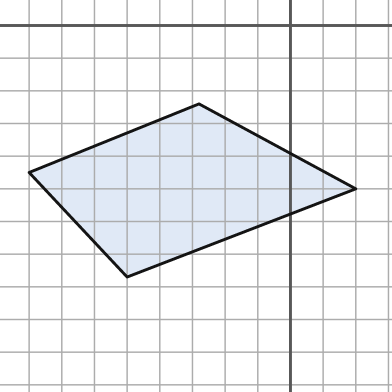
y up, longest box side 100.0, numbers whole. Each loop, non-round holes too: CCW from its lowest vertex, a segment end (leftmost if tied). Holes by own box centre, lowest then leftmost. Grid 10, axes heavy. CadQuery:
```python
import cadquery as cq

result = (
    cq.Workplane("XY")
    .moveTo(-50.0, -77.0)
    .lineTo(20.0, -50.0)
    .lineTo(-28.0, -24.0)
    .lineTo(-80.0, -45.0)
    .close()
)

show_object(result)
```